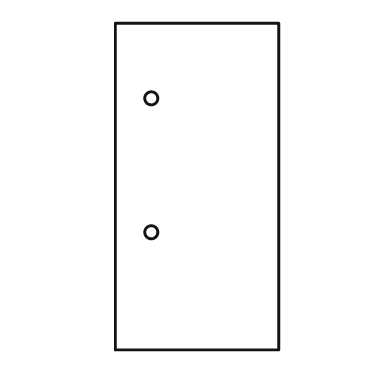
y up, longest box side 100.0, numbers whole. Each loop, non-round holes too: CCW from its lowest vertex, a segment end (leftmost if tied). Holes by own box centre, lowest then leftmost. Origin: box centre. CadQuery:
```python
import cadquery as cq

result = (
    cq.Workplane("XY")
    .moveTo(-25.0, -50.0)
    .lineTo(25.0, -50.0)
    .lineTo(25.0, 50.0)
    .lineTo(-25.0, 50.0)
    .close()
    .moveTo(-14.0, -14.0)
    .circle(2.0)
    .moveTo(-14.0, 27.0)
    .circle(2.0)
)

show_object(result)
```